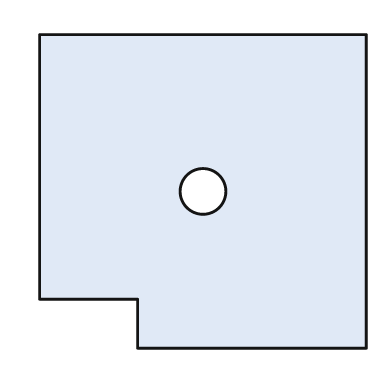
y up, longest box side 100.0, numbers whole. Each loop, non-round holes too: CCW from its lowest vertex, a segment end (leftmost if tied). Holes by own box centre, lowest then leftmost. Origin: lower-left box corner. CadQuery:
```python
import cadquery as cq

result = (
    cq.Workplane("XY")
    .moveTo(30.0, 0.0)
    .lineTo(100.0, 0.0)
    .lineTo(100.0, 96.0)
    .lineTo(0.0, 96.0)
    .lineTo(0.0, 15.0)
    .lineTo(30.0, 15.0)
    .close()
    .moveTo(50.0, 48.0)
    .circle(7.0)
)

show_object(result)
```